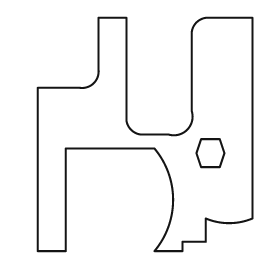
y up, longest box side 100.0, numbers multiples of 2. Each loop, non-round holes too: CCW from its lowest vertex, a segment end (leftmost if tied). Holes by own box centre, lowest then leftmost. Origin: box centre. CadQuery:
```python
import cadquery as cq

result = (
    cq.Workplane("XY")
    .moveTo(-46.0, -50.0)
    .lineTo(-34.0, -50.0)
    .lineTo(-34.0, -6.0)
    .lineTo(4.0, -6.0)
    .threePointArc((12.0, -28.0), (4.0, -50.0))
    .lineTo(16.0, -50.0)
    .lineTo(16.0, -46.0)
    .lineTo(26.0, -46.0)
    .lineTo(26.0, -36.0)
    .threePointArc((36.0, -38.0), (46.0, -36.0))
    .lineTo(46.0, 50.0)
    .lineTo(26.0, 50.0)
    .threePointArc((22.0, 48.0), (20.0, 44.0))
    .lineTo(20.0, 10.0)
    .threePointArc((18.0, 2.0), (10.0, 0.0))
    .lineTo(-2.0, 0.0)
    .threePointArc((-6.0, 2.0), (-8.0, 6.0))
    .lineTo(-8.0, 50.0)
    .lineTo(-20.0, 50.0)
    .lineTo(-20.0, 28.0)
    .threePointArc((-22.0, 22.0), (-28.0, 20.0))
    .lineTo(-46.0, 20.0)
    .close()
    .moveTo(24.0, -14.0)
    .lineTo(32.0, -14.0)
    .lineTo(34.0, -8.0)
    .lineTo(32.0, -2.0)
    .lineTo(24.0, -2.0)
    .lineTo(22.0, -8.0)
    .close()
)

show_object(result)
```